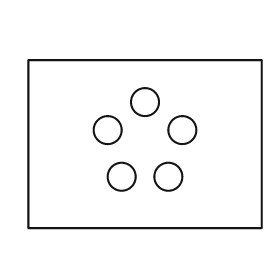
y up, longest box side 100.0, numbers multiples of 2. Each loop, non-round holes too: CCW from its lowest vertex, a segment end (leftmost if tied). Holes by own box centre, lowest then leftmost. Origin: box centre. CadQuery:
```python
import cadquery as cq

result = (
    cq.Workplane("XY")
    .moveTo(-50.0, -36.0)
    .lineTo(50.0, -36.0)
    .lineTo(50.0, 36.0)
    .lineTo(-50.0, 36.0)
    .close()
    .moveTo(-10.0, -14.0)
    .circle(6.0)
    .moveTo(10.0, -14.0)
    .circle(6.0)
    .moveTo(-16.0, 6.0)
    .circle(6.0)
    .moveTo(16.0, 6.0)
    .circle(6.0)
    .moveTo(0.0, 18.0)
    .circle(6.0)
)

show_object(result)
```